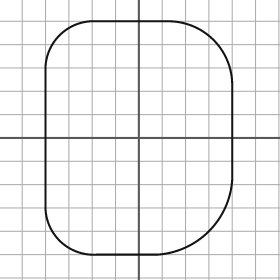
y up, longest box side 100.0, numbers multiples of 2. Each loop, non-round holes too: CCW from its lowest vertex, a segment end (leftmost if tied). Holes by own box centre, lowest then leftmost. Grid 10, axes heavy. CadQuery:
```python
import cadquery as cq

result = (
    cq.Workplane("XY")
    .moveTo(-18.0, -50.0)
    .lineTo(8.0, -50.0)
    .threePointArc((30.0, -40.0), (40.0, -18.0))
    .lineTo(40.0, 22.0)
    .threePointArc((32.0, 42.0), (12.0, 50.0))
    .lineTo(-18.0, 50.0)
    .threePointArc((-34.0, 44.0), (-40.0, 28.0))
    .lineTo(-40.0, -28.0)
    .threePointArc((-34.0, -44.0), (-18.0, -50.0))
    .close()
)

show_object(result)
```